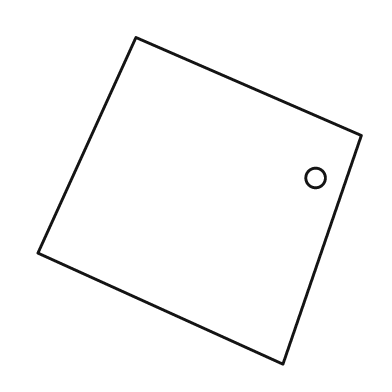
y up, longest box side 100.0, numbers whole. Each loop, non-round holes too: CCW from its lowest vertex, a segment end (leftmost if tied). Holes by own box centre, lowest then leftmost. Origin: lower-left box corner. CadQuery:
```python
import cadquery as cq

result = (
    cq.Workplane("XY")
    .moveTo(75.0, 0.0)
    .lineTo(99.0, 70.0)
    .lineTo(30.0, 100.0)
    .lineTo(0.0, 34.0)
    .close()
    .moveTo(85.0, 57.0)
    .circle(3.0)
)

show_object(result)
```